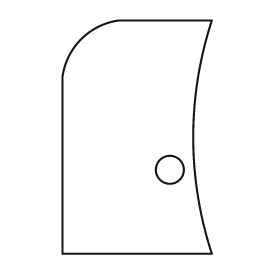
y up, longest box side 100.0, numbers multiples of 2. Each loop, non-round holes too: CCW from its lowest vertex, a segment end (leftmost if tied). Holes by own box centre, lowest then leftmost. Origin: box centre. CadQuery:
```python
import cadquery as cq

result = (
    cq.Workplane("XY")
    .moveTo(-32.0, -50.0)
    .lineTo(32.0, -50.0)
    .threePointArc((24.0, 0.0), (32.0, 50.0))
    .lineTo(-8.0, 50.0)
    .threePointArc((-24.0, 42.0), (-32.0, 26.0))
    .close()
    .moveTo(14.0, -14.0)
    .circle(6.0)
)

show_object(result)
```